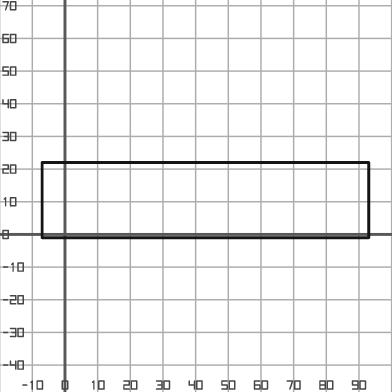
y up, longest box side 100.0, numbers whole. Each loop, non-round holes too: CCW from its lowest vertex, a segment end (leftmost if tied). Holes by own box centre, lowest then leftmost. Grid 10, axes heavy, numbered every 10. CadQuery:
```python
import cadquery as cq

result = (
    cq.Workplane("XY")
    .moveTo(-7.0, -1.0)
    .lineTo(93.0, -1.0)
    .lineTo(93.0, 22.0)
    .lineTo(-7.0, 22.0)
    .close()
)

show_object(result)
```